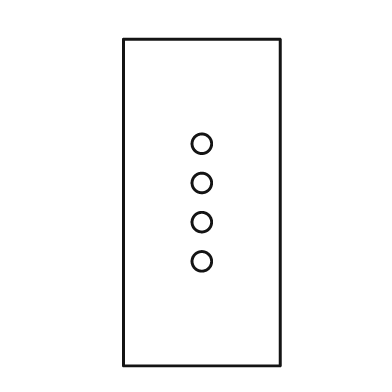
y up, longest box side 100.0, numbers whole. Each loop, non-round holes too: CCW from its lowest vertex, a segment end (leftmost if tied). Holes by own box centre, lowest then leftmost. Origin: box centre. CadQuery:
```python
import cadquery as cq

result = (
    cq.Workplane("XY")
    .moveTo(-24.0, -50.0)
    .lineTo(24.0, -50.0)
    .lineTo(24.0, 50.0)
    .lineTo(-24.0, 50.0)
    .close()
    .moveTo(0.0, -18.0)
    .circle(3.0)
    .moveTo(0.0, -6.0)
    .circle(3.0)
    .moveTo(0.0, 6.0)
    .circle(3.0)
    .moveTo(0.0, 18.0)
    .circle(3.0)
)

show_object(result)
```